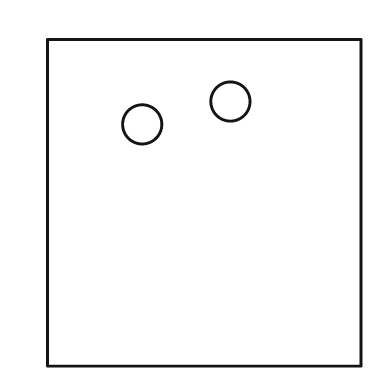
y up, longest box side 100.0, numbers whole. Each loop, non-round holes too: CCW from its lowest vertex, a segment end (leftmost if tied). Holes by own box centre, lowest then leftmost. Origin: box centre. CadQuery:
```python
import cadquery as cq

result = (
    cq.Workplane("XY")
    .moveTo(-48.0, -50.0)
    .lineTo(48.0, -50.0)
    .lineTo(48.0, 50.0)
    .lineTo(-48.0, 50.0)
    .close()
    .moveTo(-19.0, 24.0)
    .circle(6.0)
    .moveTo(8.0, 31.0)
    .circle(6.0)
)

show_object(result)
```